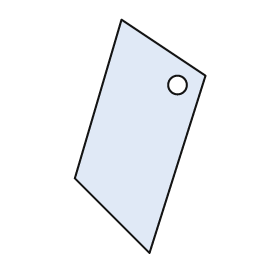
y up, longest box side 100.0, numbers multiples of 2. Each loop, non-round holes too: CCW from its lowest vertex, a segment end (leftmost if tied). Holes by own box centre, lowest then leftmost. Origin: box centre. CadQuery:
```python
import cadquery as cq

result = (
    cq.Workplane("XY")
    .moveTo(4.0, -50.0)
    .lineTo(28.0, 26.0)
    .lineTo(-8.0, 50.0)
    .lineTo(-28.0, -18.0)
    .close()
    .moveTo(16.0, 22.0)
    .circle(4.0)
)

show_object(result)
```